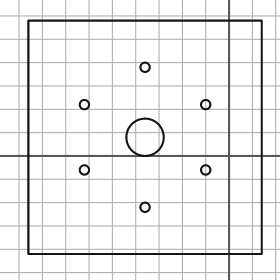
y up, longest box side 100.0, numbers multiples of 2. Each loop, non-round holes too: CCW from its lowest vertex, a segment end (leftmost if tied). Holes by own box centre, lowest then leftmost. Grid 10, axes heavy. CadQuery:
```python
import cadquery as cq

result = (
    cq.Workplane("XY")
    .moveTo(-86.0, -42.0)
    .lineTo(14.0, -42.0)
    .lineTo(14.0, 58.0)
    .lineTo(-86.0, 58.0)
    .close()
    .moveTo(-36.0, -22.0)
    .circle(2.0)
    .moveTo(-62.0, -6.0)
    .circle(2.0)
    .moveTo(-10.0, -6.0)
    .circle(2.0)
    .moveTo(-36.0, 8.0)
    .circle(8.0)
    .moveTo(-62.0, 22.0)
    .circle(2.0)
    .moveTo(-10.0, 22.0)
    .circle(2.0)
    .moveTo(-36.0, 38.0)
    .circle(2.0)
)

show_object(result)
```